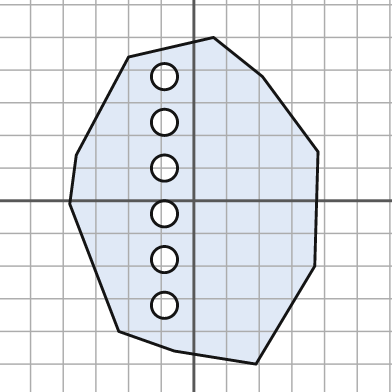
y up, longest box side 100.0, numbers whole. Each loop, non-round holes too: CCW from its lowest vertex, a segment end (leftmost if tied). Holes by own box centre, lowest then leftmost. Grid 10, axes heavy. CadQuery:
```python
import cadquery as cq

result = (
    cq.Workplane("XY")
    .moveTo(19.0, -50.0)
    .lineTo(37.0, -20.0)
    .lineTo(38.0, 15.0)
    .lineTo(21.0, 38.0)
    .lineTo(6.0, 50.0)
    .lineTo(-20.0, 44.0)
    .lineTo(-36.0, 14.0)
    .lineTo(-38.0, -1.0)
    .lineTo(-23.0, -40.0)
    .lineTo(-6.0, -46.0)
    .close()
    .moveTo(-9.0, -32.0)
    .circle(4.0)
    .moveTo(-9.0, -18.0)
    .circle(4.0)
    .moveTo(-9.0, -4.0)
    .circle(4.0)
    .moveTo(-9.0, 10.0)
    .circle(4.0)
    .moveTo(-9.0, 24.0)
    .circle(4.0)
    .moveTo(-9.0, 38.0)
    .circle(4.0)
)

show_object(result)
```